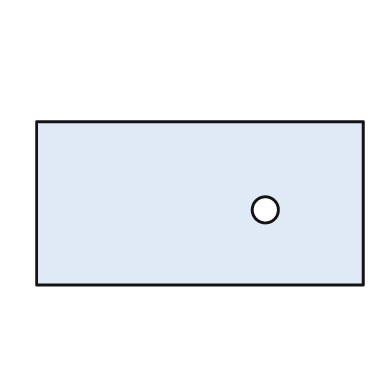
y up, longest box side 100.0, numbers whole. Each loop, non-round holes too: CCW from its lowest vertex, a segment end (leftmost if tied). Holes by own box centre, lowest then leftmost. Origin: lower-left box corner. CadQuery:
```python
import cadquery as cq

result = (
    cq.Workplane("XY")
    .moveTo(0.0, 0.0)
    .lineTo(100.0, 0.0)
    .lineTo(100.0, 50.0)
    .lineTo(0.0, 50.0)
    .close()
    .moveTo(70.0, 23.0)
    .circle(4.0)
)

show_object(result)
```